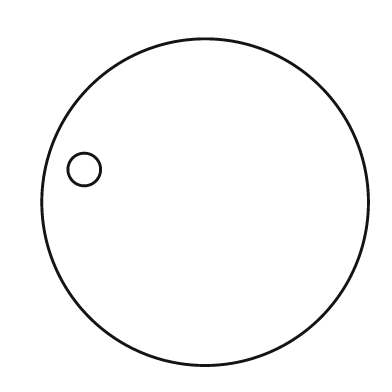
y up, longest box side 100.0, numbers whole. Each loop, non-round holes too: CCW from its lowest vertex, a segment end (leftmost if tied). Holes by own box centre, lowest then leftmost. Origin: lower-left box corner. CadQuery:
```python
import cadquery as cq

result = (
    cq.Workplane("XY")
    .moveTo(50.0, 50.0)
    .circle(50.0)
    .moveTo(13.0, 60.0)
    .circle(5.0)
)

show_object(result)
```